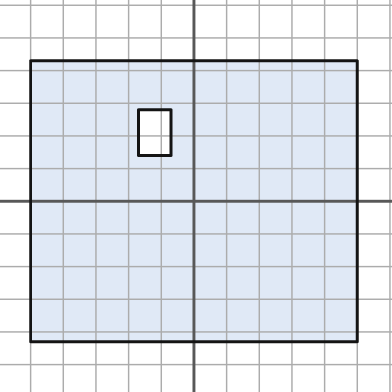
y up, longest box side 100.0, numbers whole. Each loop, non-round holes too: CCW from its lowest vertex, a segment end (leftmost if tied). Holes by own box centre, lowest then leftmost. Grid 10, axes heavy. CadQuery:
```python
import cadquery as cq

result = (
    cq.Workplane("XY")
    .moveTo(-50.0, -43.0)
    .lineTo(50.0, -43.0)
    .lineTo(50.0, 43.0)
    .lineTo(-50.0, 43.0)
    .close()
    .moveTo(-17.0, 14.0)
    .lineTo(-7.0, 14.0)
    .lineTo(-7.0, 28.0)
    .lineTo(-17.0, 28.0)
    .close()
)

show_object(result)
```